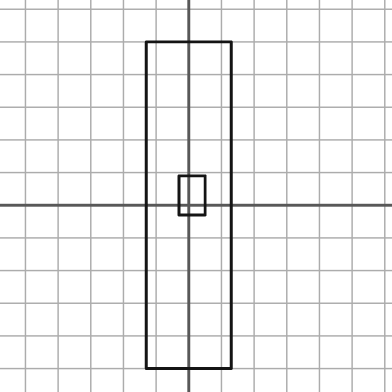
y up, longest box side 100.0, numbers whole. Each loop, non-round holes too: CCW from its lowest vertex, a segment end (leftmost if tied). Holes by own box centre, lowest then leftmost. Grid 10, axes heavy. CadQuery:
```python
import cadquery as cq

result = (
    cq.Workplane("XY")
    .moveTo(-13.0, -50.0)
    .lineTo(13.0, -50.0)
    .lineTo(13.0, 50.0)
    .lineTo(-13.0, 50.0)
    .close()
    .moveTo(-3.0, -3.0)
    .lineTo(5.0, -3.0)
    .lineTo(5.0, 9.0)
    .lineTo(-3.0, 9.0)
    .close()
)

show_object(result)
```